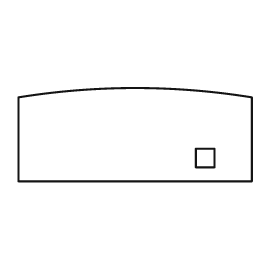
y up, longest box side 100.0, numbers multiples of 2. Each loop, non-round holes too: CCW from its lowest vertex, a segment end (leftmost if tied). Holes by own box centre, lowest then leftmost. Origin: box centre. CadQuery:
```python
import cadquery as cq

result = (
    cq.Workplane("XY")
    .moveTo(-50.0, -20.0)
    .lineTo(50.0, -20.0)
    .lineTo(50.0, 16.0)
    .threePointArc((0.0, 20.0), (-50.0, 16.0))
    .close()
    .moveTo(26.0, -14.0)
    .lineTo(34.0, -14.0)
    .lineTo(34.0, -6.0)
    .lineTo(26.0, -6.0)
    .close()
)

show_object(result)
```